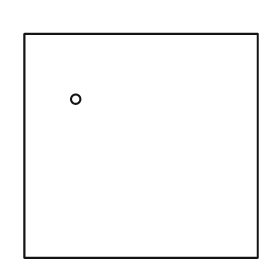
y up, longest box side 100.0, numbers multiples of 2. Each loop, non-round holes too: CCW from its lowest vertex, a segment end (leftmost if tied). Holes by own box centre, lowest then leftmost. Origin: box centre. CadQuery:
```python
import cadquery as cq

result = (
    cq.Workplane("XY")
    .moveTo(-50.0, -48.0)
    .lineTo(50.0, -48.0)
    .lineTo(50.0, 48.0)
    .lineTo(-50.0, 48.0)
    .close()
    .moveTo(-28.0, 20.0)
    .circle(2.0)
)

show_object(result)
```